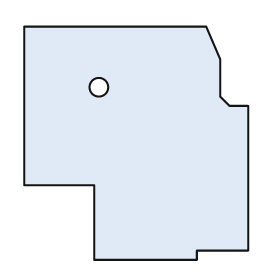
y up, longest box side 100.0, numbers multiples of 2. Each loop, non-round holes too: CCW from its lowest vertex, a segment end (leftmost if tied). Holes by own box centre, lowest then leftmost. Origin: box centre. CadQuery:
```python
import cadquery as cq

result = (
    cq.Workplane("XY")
    .moveTo(-18.0, -50.0)
    .lineTo(26.0, -50.0)
    .lineTo(26.0, -46.0)
    .lineTo(48.0, -46.0)
    .lineTo(48.0, 16.0)
    .lineTo(40.0, 16.0)
    .lineTo(36.0, 20.0)
    .lineTo(36.0, 36.0)
    .lineTo(30.0, 50.0)
    .lineTo(-48.0, 50.0)
    .lineTo(-48.0, -18.0)
    .lineTo(-18.0, -18.0)
    .close()
    .moveTo(-16.0, 24.0)
    .circle(4.0)
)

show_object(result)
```